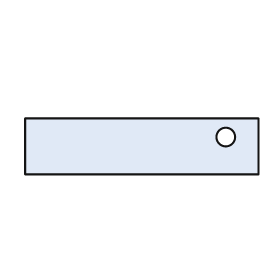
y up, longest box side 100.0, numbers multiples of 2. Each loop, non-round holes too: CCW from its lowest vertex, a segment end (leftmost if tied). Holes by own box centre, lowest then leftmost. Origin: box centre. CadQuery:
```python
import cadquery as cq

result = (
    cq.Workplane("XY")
    .moveTo(-50.0, -12.0)
    .lineTo(50.0, -12.0)
    .lineTo(50.0, 12.0)
    .lineTo(-50.0, 12.0)
    .close()
    .moveTo(36.0, 4.0)
    .circle(4.0)
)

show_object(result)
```